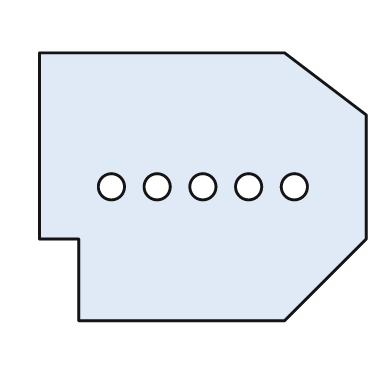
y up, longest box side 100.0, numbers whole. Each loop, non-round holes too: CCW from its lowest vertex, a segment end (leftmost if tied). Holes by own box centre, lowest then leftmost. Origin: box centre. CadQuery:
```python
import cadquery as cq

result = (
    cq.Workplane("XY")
    .moveTo(-38.0, -41.0)
    .lineTo(25.0, -41.0)
    .lineTo(50.0, -16.0)
    .lineTo(50.0, 22.0)
    .lineTo(25.0, 41.0)
    .lineTo(-50.0, 41.0)
    .lineTo(-50.0, -16.0)
    .lineTo(-38.0, -16.0)
    .close()
    .moveTo(-28.0, 0.0)
    .circle(4.0)
    .moveTo(-14.0, 0.0)
    .circle(4.0)
    .moveTo(0.0, 0.0)
    .circle(4.0)
    .moveTo(14.0, 0.0)
    .circle(4.0)
    .moveTo(28.0, 0.0)
    .circle(4.0)
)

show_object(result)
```